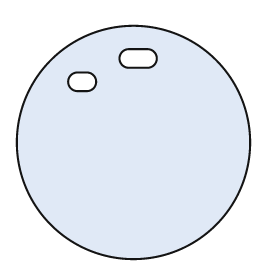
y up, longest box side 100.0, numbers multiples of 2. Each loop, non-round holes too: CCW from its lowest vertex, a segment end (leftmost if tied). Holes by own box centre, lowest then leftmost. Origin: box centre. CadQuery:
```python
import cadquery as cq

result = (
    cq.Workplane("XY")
    .moveTo(0.0, 0.0)
    .circle(50.0)
    .moveTo(-24.0, 22.0)
    .lineTo(-20.0, 22.0)
    .threePointArc((-16.0, 26.0), (-20.0, 30.0))
    .lineTo(-24.0, 30.0)
    .threePointArc((-28.0, 26.0), (-24.0, 22.0))
    .close()
    .moveTo(-2.0, 32.0)
    .lineTo(6.0, 32.0)
    .threePointArc((10.0, 36.0), (6.0, 40.0))
    .lineTo(-2.0, 40.0)
    .threePointArc((-6.0, 36.0), (-2.0, 32.0))
    .close()
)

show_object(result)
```